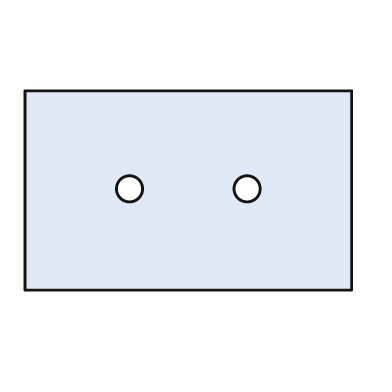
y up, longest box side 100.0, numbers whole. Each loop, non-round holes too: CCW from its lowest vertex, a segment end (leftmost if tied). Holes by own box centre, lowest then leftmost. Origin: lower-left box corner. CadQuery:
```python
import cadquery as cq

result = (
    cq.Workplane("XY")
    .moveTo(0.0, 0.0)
    .lineTo(100.0, 0.0)
    .lineTo(100.0, 61.0)
    .lineTo(0.0, 61.0)
    .close()
    .moveTo(32.0, 31.0)
    .circle(4.0)
    .moveTo(68.0, 31.0)
    .circle(4.0)
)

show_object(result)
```